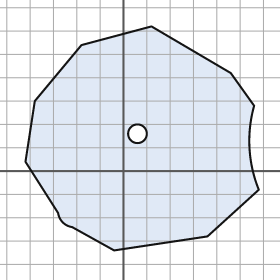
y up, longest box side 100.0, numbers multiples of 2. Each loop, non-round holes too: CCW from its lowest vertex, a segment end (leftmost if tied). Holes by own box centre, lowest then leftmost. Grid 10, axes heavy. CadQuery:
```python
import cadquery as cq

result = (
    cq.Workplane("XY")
    .moveTo(-4.0, -34.0)
    .lineTo(36.0, -28.0)
    .lineTo(58.0, -8.0)
    .threePointArc((54.0, 10.0), (56.0, 28.0))
    .lineTo(46.0, 42.0)
    .lineTo(12.0, 62.0)
    .lineTo(-18.0, 54.0)
    .lineTo(-38.0, 30.0)
    .lineTo(-42.0, 4.0)
    .lineTo(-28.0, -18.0)
    .threePointArc((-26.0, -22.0), (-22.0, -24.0))
    .close()
    .moveTo(6.0, 16.0)
    .circle(4.0)
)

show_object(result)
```